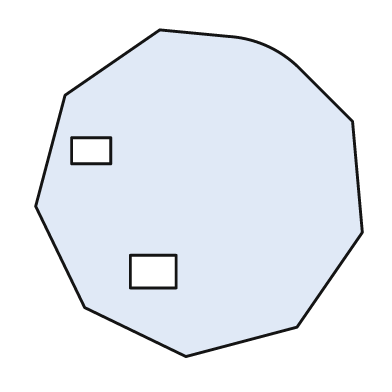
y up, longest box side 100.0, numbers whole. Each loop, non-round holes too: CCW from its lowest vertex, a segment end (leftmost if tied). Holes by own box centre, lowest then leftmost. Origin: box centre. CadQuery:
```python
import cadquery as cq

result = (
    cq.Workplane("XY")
    .moveTo(-4.0, -50.0)
    .lineTo(30.0, -41.0)
    .lineTo(50.0, -12.0)
    .lineTo(47.0, 22.0)
    .lineTo(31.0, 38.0)
    .threePointArc((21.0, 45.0), (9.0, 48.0))
    .lineTo(-12.0, 50.0)
    .lineTo(-41.0, 30.0)
    .lineTo(-50.0, -4.0)
    .lineTo(-35.0, -35.0)
    .close()
    .moveTo(-21.0, -29.0)
    .lineTo(-7.0, -29.0)
    .lineTo(-7.0, -19.0)
    .lineTo(-21.0, -19.0)
    .close()
    .moveTo(-39.0, 9.0)
    .lineTo(-27.0, 9.0)
    .lineTo(-27.0, 17.0)
    .lineTo(-39.0, 17.0)
    .close()
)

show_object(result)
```